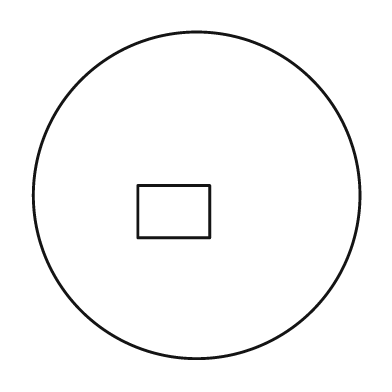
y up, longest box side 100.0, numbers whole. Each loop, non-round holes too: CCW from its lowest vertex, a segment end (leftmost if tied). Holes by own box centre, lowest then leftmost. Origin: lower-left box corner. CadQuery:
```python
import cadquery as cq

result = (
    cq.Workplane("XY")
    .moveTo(50.0, 50.0)
    .circle(50.0)
    .moveTo(32.0, 37.0)
    .lineTo(54.0, 37.0)
    .lineTo(54.0, 53.0)
    .lineTo(32.0, 53.0)
    .close()
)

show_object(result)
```